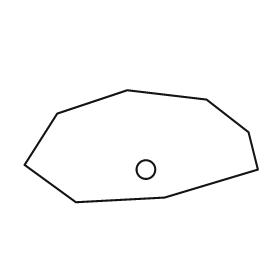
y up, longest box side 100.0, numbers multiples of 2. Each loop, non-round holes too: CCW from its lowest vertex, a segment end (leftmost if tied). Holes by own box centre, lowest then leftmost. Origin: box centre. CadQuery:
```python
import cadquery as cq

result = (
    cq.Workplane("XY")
    .moveTo(-28.0, -24.0)
    .lineTo(10.0, -22.0)
    .lineTo(50.0, -10.0)
    .lineTo(46.0, 6.0)
    .lineTo(28.0, 20.0)
    .lineTo(-6.0, 24.0)
    .lineTo(-36.0, 14.0)
    .lineTo(-50.0, -8.0)
    .close()
    .moveTo(2.0, -10.0)
    .circle(4.0)
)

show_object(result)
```